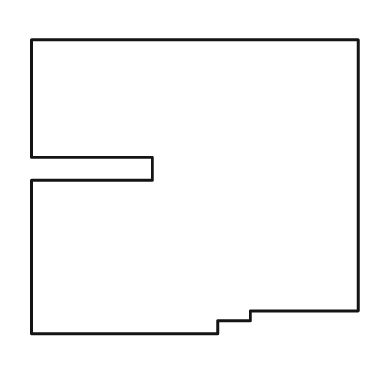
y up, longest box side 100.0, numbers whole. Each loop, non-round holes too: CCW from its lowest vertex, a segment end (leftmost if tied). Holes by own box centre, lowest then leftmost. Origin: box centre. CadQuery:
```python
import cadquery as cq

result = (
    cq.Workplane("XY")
    .moveTo(-50.0, -45.0)
    .lineTo(7.0, -45.0)
    .lineTo(7.0, -41.0)
    .lineTo(17.0, -41.0)
    .lineTo(17.0, -38.0)
    .lineTo(50.0, -38.0)
    .lineTo(50.0, 45.0)
    .lineTo(-50.0, 45.0)
    .lineTo(-50.0, 9.0)
    .lineTo(-13.0, 9.0)
    .lineTo(-13.0, 2.0)
    .lineTo(-50.0, 2.0)
    .close()
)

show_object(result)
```